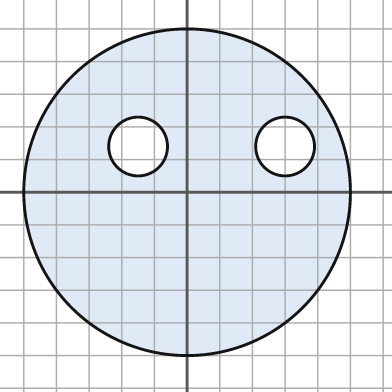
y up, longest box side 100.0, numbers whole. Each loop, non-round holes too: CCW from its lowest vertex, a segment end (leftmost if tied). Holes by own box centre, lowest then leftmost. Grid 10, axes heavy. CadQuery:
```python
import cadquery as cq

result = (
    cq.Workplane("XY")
    .moveTo(0.0, 0.0)
    .circle(50.0)
    .moveTo(-15.0, 14.0)
    .circle(9.0)
    .moveTo(30.0, 14.0)
    .circle(9.0)
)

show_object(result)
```